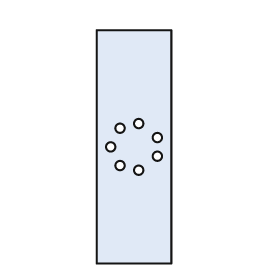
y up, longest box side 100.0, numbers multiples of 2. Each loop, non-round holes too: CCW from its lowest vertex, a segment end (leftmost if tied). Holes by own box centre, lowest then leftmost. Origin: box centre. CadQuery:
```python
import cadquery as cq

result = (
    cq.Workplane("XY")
    .moveTo(-16.0, -50.0)
    .lineTo(16.0, -50.0)
    .lineTo(16.0, 50.0)
    .lineTo(-16.0, 50.0)
    .close()
    .moveTo(2.0, -10.0)
    .circle(2.0)
    .moveTo(-6.0, -8.0)
    .circle(2.0)
    .moveTo(10.0, -4.0)
    .circle(2.0)
    .moveTo(-10.0, 0.0)
    .circle(2.0)
    .moveTo(10.0, 4.0)
    .circle(2.0)
    .moveTo(-6.0, 8.0)
    .circle(2.0)
    .moveTo(2.0, 10.0)
    .circle(2.0)
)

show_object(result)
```